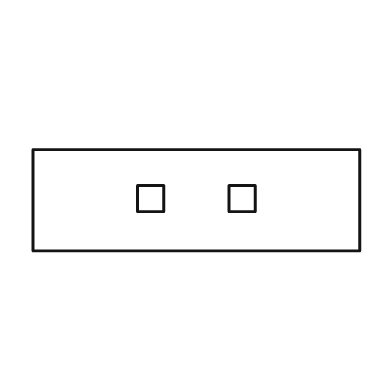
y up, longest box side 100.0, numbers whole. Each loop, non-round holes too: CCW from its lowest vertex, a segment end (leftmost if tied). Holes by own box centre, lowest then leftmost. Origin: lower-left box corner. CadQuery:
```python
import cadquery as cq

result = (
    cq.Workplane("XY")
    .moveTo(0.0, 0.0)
    .lineTo(100.0, 0.0)
    .lineTo(100.0, 31.0)
    .lineTo(0.0, 31.0)
    .close()
    .moveTo(32.0, 12.0)
    .lineTo(40.0, 12.0)
    .lineTo(40.0, 20.0)
    .lineTo(32.0, 20.0)
    .close()
    .moveTo(60.0, 12.0)
    .lineTo(68.0, 12.0)
    .lineTo(68.0, 20.0)
    .lineTo(60.0, 20.0)
    .close()
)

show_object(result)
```